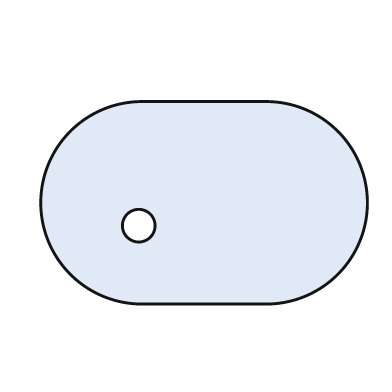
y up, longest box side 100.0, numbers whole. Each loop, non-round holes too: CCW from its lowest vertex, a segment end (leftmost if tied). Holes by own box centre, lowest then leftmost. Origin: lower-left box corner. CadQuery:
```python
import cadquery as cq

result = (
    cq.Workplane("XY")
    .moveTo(31.0, 0.0)
    .lineTo(69.0, 0.0)
    .threePointArc((100.0, 31.0), (69.0, 62.0))
    .lineTo(31.0, 62.0)
    .threePointArc((0.0, 31.0), (31.0, 0.0))
    .close()
    .moveTo(30.0, 24.0)
    .circle(5.0)
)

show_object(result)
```